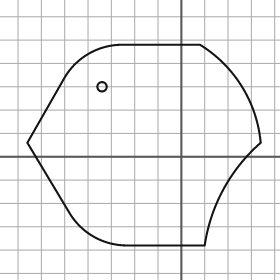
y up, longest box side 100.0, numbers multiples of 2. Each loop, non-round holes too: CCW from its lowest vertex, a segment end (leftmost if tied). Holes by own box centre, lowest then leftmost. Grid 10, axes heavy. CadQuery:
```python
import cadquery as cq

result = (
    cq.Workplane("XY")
    .moveTo(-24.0, -38.0)
    .lineTo(10.0, -38.0)
    .threePointArc((18.0, -14.0), (34.0, 6.0))
    .threePointArc((26.0, 30.0), (8.0, 48.0))
    .lineTo(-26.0, 48.0)
    .threePointArc((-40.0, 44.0), (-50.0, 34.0))
    .lineTo(-66.0, 6.0)
    .lineTo(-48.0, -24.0)
    .threePointArc((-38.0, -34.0), (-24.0, -38.0))
    .close()
    .moveTo(-34.0, 30.0)
    .circle(2.0)
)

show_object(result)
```